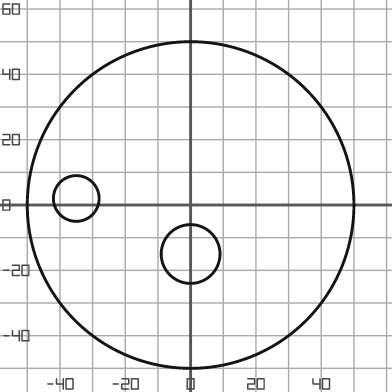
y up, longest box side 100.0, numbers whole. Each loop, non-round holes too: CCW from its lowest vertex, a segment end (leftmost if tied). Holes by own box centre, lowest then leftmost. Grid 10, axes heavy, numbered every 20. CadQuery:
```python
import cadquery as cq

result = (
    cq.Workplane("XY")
    .moveTo(0.0, 0.0)
    .circle(50.0)
    .moveTo(0.0, -15.0)
    .circle(9.0)
    .moveTo(-35.0, 2.0)
    .circle(7.0)
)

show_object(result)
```